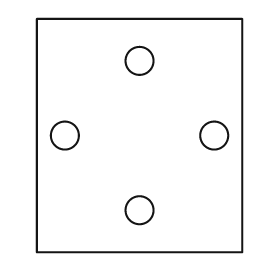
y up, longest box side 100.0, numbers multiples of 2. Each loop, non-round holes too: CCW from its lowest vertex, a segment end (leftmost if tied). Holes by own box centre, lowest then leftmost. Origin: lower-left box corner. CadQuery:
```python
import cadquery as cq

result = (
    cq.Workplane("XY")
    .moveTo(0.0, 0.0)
    .lineTo(88.0, 0.0)
    .lineTo(88.0, 100.0)
    .lineTo(0.0, 100.0)
    .close()
    .moveTo(44.0, 18.0)
    .circle(6.0)
    .moveTo(12.0, 50.0)
    .circle(6.0)
    .moveTo(76.0, 50.0)
    .circle(6.0)
    .moveTo(44.0, 82.0)
    .circle(6.0)
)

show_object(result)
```